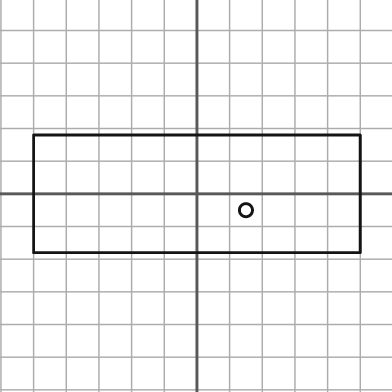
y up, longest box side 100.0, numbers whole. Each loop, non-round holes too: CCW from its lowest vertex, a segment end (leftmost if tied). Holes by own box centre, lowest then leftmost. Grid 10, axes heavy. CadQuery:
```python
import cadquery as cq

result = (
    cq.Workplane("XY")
    .moveTo(-50.0, -18.0)
    .lineTo(50.0, -18.0)
    .lineTo(50.0, 18.0)
    .lineTo(-50.0, 18.0)
    .close()
    .moveTo(15.0, -5.0)
    .circle(2.0)
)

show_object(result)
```